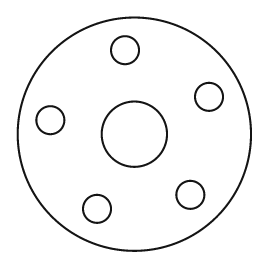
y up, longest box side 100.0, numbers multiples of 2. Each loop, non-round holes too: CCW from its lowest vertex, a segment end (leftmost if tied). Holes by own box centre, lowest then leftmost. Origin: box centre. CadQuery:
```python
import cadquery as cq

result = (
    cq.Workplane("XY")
    .moveTo(0.0, 0.0)
    .circle(50.0)
    .moveTo(-16.0, -32.0)
    .circle(6.0)
    .moveTo(24.0, -26.0)
    .circle(6.0)
    .moveTo(0.0, 0.0)
    .circle(14.0)
    .moveTo(-36.0, 6.0)
    .circle(6.0)
    .moveTo(32.0, 16.0)
    .circle(6.0)
    .moveTo(-4.0, 36.0)
    .circle(6.0)
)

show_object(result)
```